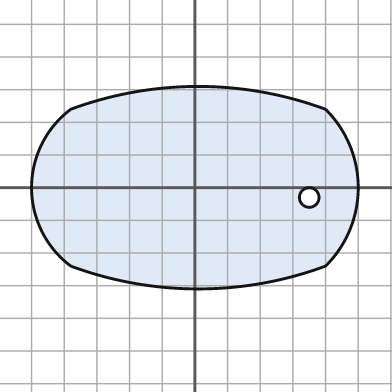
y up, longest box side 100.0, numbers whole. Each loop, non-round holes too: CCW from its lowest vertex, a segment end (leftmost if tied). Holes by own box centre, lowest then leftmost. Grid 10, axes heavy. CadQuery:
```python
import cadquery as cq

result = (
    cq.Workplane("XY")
    .moveTo(-38.0, -24.0)
    .threePointArc((1.0, -31.0), (40.0, -24.0))
    .threePointArc((50.0, 0.0), (40.0, 24.0))
    .threePointArc((1.0, 31.0), (-38.0, 24.0))
    .threePointArc((-50.0, 0.0), (-38.0, -24.0))
    .close()
    .moveTo(35.0, -3.0)
    .circle(3.0)
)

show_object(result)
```